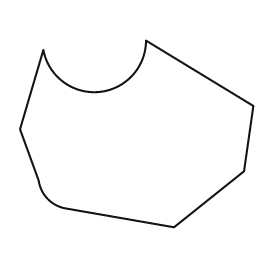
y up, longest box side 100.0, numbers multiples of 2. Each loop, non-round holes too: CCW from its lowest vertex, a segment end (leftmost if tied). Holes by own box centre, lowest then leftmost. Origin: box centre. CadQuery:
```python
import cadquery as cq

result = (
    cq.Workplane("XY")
    .moveTo(16.0, -40.0)
    .lineTo(46.0, -16.0)
    .lineTo(50.0, 12.0)
    .lineTo(4.0, 40.0)
    .threePointArc((-16.0, 18.0), (-40.0, 36.0))
    .lineTo(-50.0, 2.0)
    .lineTo(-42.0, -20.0)
    .threePointArc((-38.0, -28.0), (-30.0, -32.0))
    .close()
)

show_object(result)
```